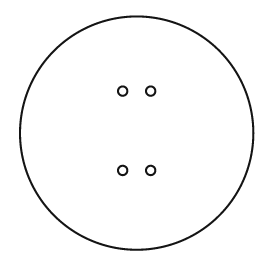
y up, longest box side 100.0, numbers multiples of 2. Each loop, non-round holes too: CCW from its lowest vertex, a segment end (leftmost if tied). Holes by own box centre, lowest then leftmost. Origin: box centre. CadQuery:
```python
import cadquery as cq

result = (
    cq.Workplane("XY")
    .moveTo(0.0, 0.0)
    .circle(50.0)
    .moveTo(-6.0, -16.0)
    .circle(2.0)
    .moveTo(6.0, -16.0)
    .circle(2.0)
    .moveTo(-6.0, 18.0)
    .circle(2.0)
    .moveTo(6.0, 18.0)
    .circle(2.0)
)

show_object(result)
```